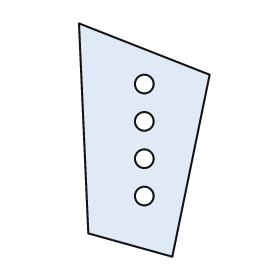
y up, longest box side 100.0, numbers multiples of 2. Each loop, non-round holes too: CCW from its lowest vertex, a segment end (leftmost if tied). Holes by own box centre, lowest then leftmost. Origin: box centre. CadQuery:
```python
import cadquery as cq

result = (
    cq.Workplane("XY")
    .moveTo(12.0, -50.0)
    .lineTo(28.0, 28.0)
    .lineTo(-28.0, 50.0)
    .lineTo(-24.0, -40.0)
    .close()
    .moveTo(0.0, -24.0)
    .circle(4.0)
    .moveTo(0.0, -8.0)
    .circle(4.0)
    .moveTo(0.0, 8.0)
    .circle(4.0)
    .moveTo(0.0, 24.0)
    .circle(4.0)
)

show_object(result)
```